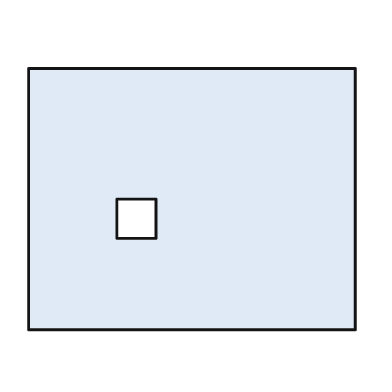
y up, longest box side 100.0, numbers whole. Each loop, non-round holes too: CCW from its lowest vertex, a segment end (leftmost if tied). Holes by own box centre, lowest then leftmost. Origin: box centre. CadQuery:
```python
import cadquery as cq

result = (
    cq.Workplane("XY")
    .moveTo(-50.0, -40.0)
    .lineTo(50.0, -40.0)
    .lineTo(50.0, 40.0)
    .lineTo(-50.0, 40.0)
    .close()
    .moveTo(-23.0, -12.0)
    .lineTo(-11.0, -12.0)
    .lineTo(-11.0, 0.0)
    .lineTo(-23.0, 0.0)
    .close()
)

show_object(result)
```